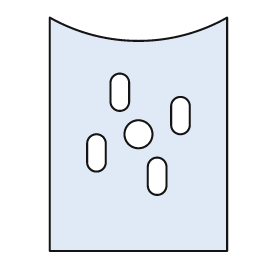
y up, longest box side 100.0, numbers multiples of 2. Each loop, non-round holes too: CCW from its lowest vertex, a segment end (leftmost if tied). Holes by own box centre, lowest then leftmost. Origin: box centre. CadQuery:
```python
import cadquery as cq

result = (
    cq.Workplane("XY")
    .moveTo(-38.0, -50.0)
    .lineTo(38.0, -50.0)
    .lineTo(38.0, 50.0)
    .threePointArc((0.0, 40.0), (-38.0, 50.0))
    .close()
    .moveTo(4.0, -22.0)
    .threePointArc((8.0, -26.0), (12.0, -22.0))
    .lineTo(12.0, -14.0)
    .threePointArc((8.0, -10.0), (4.0, -14.0))
    .close()
    .moveTo(-22.0, -12.0)
    .threePointArc((-18.0, -16.0), (-14.0, -12.0))
    .lineTo(-14.0, -4.0)
    .threePointArc((-18.0, 0.0), (-22.0, -4.0))
    .close()
    .moveTo(0.0, 0.0)
    .circle(6.0)
    .moveTo(14.0, 4.0)
    .threePointArc((18.0, 0.0), (22.0, 4.0))
    .lineTo(22.0, 12.0)
    .threePointArc((18.0, 16.0), (14.0, 12.0))
    .close()
    .moveTo(-12.0, 14.0)
    .threePointArc((-8.0, 10.0), (-4.0, 14.0))
    .lineTo(-4.0, 22.0)
    .threePointArc((-8.0, 26.0), (-12.0, 22.0))
    .close()
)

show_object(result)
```